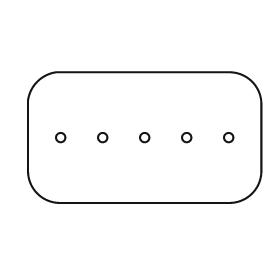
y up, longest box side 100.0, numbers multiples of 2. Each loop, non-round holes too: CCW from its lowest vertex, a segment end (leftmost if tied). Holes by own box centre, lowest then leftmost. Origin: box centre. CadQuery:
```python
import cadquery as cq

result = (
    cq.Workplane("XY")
    .moveTo(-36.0, -28.0)
    .lineTo(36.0, -28.0)
    .threePointArc((46.0, -24.0), (50.0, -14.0))
    .lineTo(50.0, 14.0)
    .threePointArc((46.0, 24.0), (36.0, 28.0))
    .lineTo(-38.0, 28.0)
    .threePointArc((-46.0, 24.0), (-50.0, 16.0))
    .lineTo(-50.0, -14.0)
    .threePointArc((-46.0, -24.0), (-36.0, -28.0))
    .close()
    .moveTo(-36.0, 0.0)
    .circle(2.0)
    .moveTo(-18.0, 0.0)
    .circle(2.0)
    .moveTo(0.0, 0.0)
    .circle(2.0)
    .moveTo(18.0, 0.0)
    .circle(2.0)
    .moveTo(36.0, 0.0)
    .circle(2.0)
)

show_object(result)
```